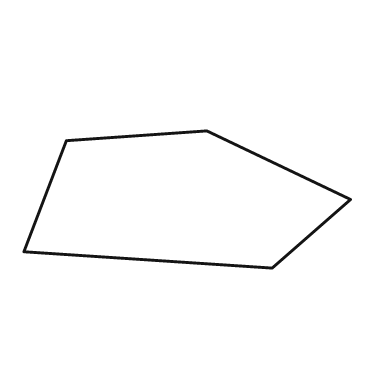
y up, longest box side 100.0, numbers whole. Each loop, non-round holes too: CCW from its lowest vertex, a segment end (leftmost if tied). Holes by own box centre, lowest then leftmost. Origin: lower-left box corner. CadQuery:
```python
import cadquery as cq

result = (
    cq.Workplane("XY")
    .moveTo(76.0, 0.0)
    .lineTo(100.0, 21.0)
    .lineTo(56.0, 42.0)
    .lineTo(13.0, 39.0)
    .lineTo(0.0, 5.0)
    .close()
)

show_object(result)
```